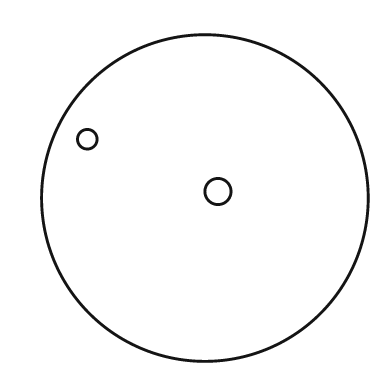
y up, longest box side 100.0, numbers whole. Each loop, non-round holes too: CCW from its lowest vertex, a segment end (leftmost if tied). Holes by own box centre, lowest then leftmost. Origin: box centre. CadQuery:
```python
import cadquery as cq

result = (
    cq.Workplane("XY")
    .moveTo(0.0, 0.0)
    .circle(50.0)
    .moveTo(4.0, 2.0)
    .circle(4.0)
    .moveTo(-36.0, 18.0)
    .circle(3.0)
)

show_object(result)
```